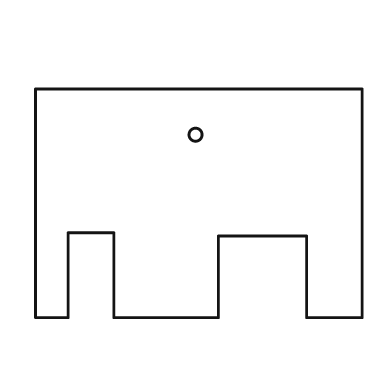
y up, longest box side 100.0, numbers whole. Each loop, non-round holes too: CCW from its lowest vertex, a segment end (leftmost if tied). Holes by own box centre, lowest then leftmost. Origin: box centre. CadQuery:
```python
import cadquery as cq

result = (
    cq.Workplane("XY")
    .moveTo(-50.0, -35.0)
    .lineTo(-40.0, -35.0)
    .lineTo(-40.0, -9.0)
    .lineTo(-26.0, -9.0)
    .lineTo(-26.0, -35.0)
    .lineTo(6.0, -35.0)
    .lineTo(6.0, -10.0)
    .lineTo(33.0, -10.0)
    .lineTo(33.0, -35.0)
    .lineTo(50.0, -35.0)
    .lineTo(50.0, 35.0)
    .lineTo(-50.0, 35.0)
    .close()
    .moveTo(-1.0, 21.0)
    .circle(2.0)
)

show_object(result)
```